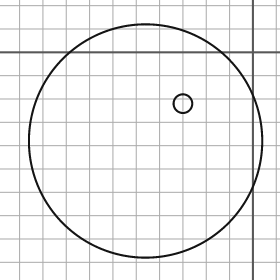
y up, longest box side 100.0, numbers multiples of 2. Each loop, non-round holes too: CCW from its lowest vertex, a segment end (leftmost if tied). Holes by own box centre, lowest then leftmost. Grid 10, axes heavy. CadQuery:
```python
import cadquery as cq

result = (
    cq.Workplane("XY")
    .moveTo(-46.0, -38.0)
    .circle(50.0)
    .moveTo(-30.0, -22.0)
    .circle(4.0)
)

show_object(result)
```